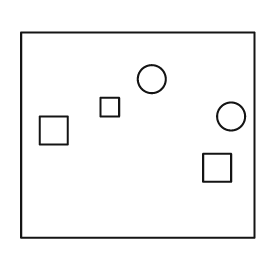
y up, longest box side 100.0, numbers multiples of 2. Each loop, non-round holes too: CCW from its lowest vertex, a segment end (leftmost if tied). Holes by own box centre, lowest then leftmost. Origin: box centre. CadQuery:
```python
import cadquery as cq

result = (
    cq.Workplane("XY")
    .moveTo(-50.0, -44.0)
    .lineTo(50.0, -44.0)
    .lineTo(50.0, 44.0)
    .lineTo(-50.0, 44.0)
    .close()
    .moveTo(28.0, -20.0)
    .lineTo(40.0, -20.0)
    .lineTo(40.0, -8.0)
    .lineTo(28.0, -8.0)
    .close()
    .moveTo(-42.0, -4.0)
    .lineTo(-30.0, -4.0)
    .lineTo(-30.0, 8.0)
    .lineTo(-42.0, 8.0)
    .close()
    .moveTo(40.0, 8.0)
    .circle(6.0)
    .moveTo(-16.0, 8.0)
    .lineTo(-8.0, 8.0)
    .lineTo(-8.0, 16.0)
    .lineTo(-16.0, 16.0)
    .close()
    .moveTo(6.0, 24.0)
    .circle(6.0)
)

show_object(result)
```